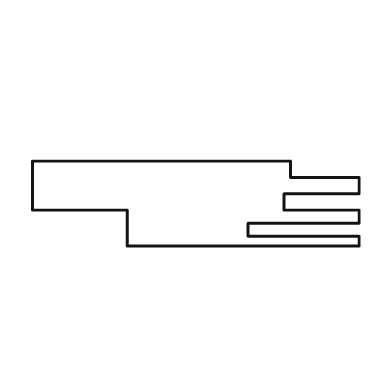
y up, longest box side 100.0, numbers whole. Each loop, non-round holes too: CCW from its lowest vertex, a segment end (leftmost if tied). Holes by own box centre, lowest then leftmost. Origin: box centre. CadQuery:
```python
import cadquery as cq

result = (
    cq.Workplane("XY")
    .moveTo(-21.0, -13.0)
    .lineTo(50.0, -13.0)
    .lineTo(50.0, -10.0)
    .lineTo(16.0, -10.0)
    .lineTo(16.0, -6.0)
    .lineTo(50.0, -6.0)
    .lineTo(50.0, -2.0)
    .lineTo(27.0, -2.0)
    .lineTo(27.0, 3.0)
    .lineTo(50.0, 3.0)
    .lineTo(50.0, 8.0)
    .lineTo(29.0, 8.0)
    .lineTo(29.0, 13.0)
    .lineTo(-50.0, 13.0)
    .lineTo(-50.0, -2.0)
    .lineTo(-21.0, -2.0)
    .close()
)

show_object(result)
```